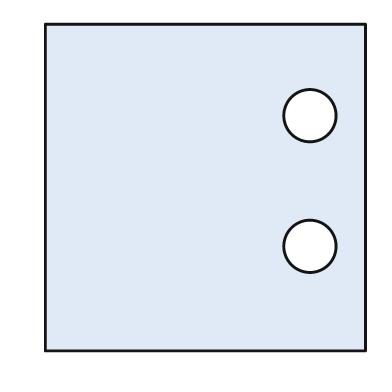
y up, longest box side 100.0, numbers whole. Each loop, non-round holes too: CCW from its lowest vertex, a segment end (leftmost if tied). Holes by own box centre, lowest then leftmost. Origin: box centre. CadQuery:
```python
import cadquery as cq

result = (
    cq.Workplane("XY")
    .moveTo(-49.0, -50.0)
    .lineTo(49.0, -50.0)
    .lineTo(49.0, 50.0)
    .lineTo(-49.0, 50.0)
    .close()
    .moveTo(32.0, -18.0)
    .circle(8.0)
    .moveTo(32.0, 22.0)
    .circle(8.0)
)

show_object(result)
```